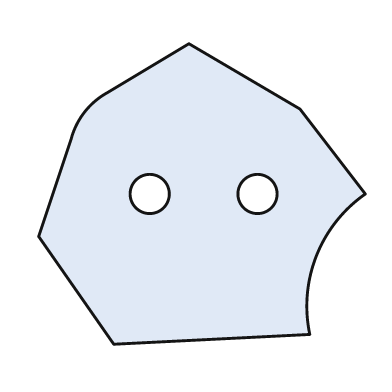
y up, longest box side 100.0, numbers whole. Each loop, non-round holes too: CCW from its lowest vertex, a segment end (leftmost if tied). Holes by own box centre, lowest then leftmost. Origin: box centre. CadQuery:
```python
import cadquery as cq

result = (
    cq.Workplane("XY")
    .moveTo(-27.0, -46.0)
    .lineTo(33.0, -43.0)
    .threePointArc((35.0, -19.0), (50.0, 0.0))
    .lineTo(30.0, 26.0)
    .lineTo(-4.0, 46.0)
    .lineTo(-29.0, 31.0)
    .threePointArc((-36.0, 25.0), (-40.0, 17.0))
    .lineTo(-50.0, -13.0)
    .close()
    .moveTo(-16.0, 0.0)
    .circle(6.0)
    .moveTo(17.0, 0.0)
    .circle(6.0)
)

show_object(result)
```